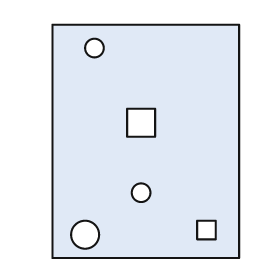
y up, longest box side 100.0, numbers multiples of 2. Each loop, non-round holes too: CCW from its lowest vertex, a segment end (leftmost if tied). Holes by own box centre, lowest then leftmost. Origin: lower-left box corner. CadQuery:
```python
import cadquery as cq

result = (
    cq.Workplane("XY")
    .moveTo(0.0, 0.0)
    .lineTo(80.0, 0.0)
    .lineTo(80.0, 100.0)
    .lineTo(0.0, 100.0)
    .close()
    .moveTo(14.0, 10.0)
    .circle(6.0)
    .moveTo(62.0, 8.0)
    .lineTo(70.0, 8.0)
    .lineTo(70.0, 16.0)
    .lineTo(62.0, 16.0)
    .close()
    .moveTo(38.0, 28.0)
    .circle(4.0)
    .moveTo(32.0, 52.0)
    .lineTo(44.0, 52.0)
    .lineTo(44.0, 64.0)
    .lineTo(32.0, 64.0)
    .close()
    .moveTo(18.0, 90.0)
    .circle(4.0)
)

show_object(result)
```